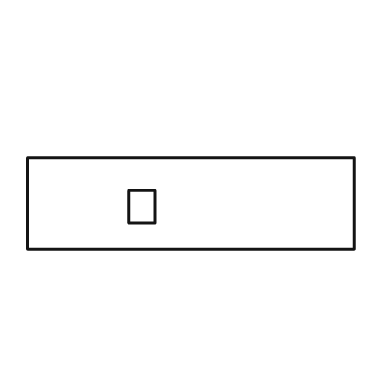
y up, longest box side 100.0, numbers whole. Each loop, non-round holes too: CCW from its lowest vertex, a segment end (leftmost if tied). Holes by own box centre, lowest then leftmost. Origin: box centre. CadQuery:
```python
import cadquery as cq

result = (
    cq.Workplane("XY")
    .moveTo(-50.0, -14.0)
    .lineTo(50.0, -14.0)
    .lineTo(50.0, 14.0)
    .lineTo(-50.0, 14.0)
    .close()
    .moveTo(-19.0, -6.0)
    .lineTo(-11.0, -6.0)
    .lineTo(-11.0, 4.0)
    .lineTo(-19.0, 4.0)
    .close()
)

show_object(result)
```